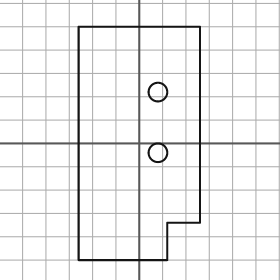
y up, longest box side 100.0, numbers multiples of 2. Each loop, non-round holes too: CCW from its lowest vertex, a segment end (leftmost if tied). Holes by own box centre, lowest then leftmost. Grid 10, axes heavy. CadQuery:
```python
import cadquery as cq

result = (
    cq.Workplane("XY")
    .moveTo(-26.0, -50.0)
    .lineTo(12.0, -50.0)
    .lineTo(12.0, -34.0)
    .lineTo(26.0, -34.0)
    .lineTo(26.0, 50.0)
    .lineTo(-26.0, 50.0)
    .close()
    .moveTo(8.0, -4.0)
    .circle(4.0)
    .moveTo(8.0, 22.0)
    .circle(4.0)
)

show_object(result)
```